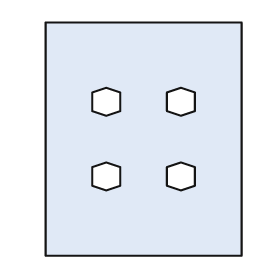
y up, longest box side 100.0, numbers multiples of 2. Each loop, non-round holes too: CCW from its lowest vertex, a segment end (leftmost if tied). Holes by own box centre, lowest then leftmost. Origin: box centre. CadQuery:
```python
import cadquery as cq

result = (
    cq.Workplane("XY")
    .moveTo(-42.0, -50.0)
    .lineTo(42.0, -50.0)
    .lineTo(42.0, 50.0)
    .lineTo(-42.0, 50.0)
    .close()
    .moveTo(-16.0, -22.0)
    .lineTo(-10.0, -20.0)
    .lineTo(-10.0, -12.0)
    .lineTo(-16.0, -10.0)
    .lineTo(-22.0, -12.0)
    .lineTo(-22.0, -20.0)
    .close()
    .moveTo(16.0, -22.0)
    .lineTo(22.0, -20.0)
    .lineTo(22.0, -12.0)
    .lineTo(16.0, -10.0)
    .lineTo(10.0, -12.0)
    .lineTo(10.0, -20.0)
    .close()
    .moveTo(-16.0, 10.0)
    .lineTo(-10.0, 12.0)
    .lineTo(-10.0, 20.0)
    .lineTo(-16.0, 22.0)
    .lineTo(-22.0, 20.0)
    .lineTo(-22.0, 12.0)
    .close()
    .moveTo(16.0, 10.0)
    .lineTo(22.0, 12.0)
    .lineTo(22.0, 20.0)
    .lineTo(16.0, 22.0)
    .lineTo(10.0, 20.0)
    .lineTo(10.0, 12.0)
    .close()
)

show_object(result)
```